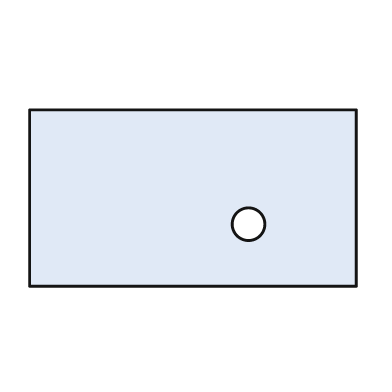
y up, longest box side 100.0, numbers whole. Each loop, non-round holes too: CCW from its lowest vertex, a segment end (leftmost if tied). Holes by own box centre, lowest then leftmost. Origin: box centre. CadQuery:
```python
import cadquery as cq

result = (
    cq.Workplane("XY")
    .moveTo(-50.0, -27.0)
    .lineTo(50.0, -27.0)
    .lineTo(50.0, 27.0)
    .lineTo(-50.0, 27.0)
    .close()
    .moveTo(17.0, -8.0)
    .circle(5.0)
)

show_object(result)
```